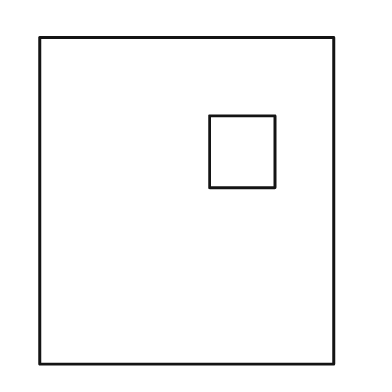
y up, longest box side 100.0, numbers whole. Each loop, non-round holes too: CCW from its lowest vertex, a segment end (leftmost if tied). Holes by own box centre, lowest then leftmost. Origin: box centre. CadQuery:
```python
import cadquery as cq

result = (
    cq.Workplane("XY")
    .moveTo(-45.0, -50.0)
    .lineTo(45.0, -50.0)
    .lineTo(45.0, 50.0)
    .lineTo(-45.0, 50.0)
    .close()
    .moveTo(7.0, 4.0)
    .lineTo(27.0, 4.0)
    .lineTo(27.0, 26.0)
    .lineTo(7.0, 26.0)
    .close()
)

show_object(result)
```